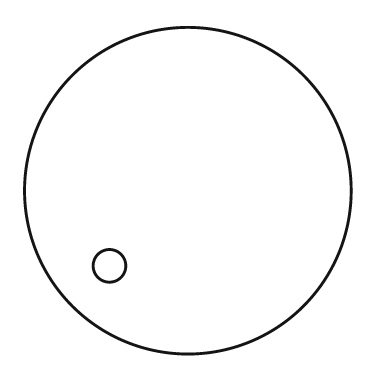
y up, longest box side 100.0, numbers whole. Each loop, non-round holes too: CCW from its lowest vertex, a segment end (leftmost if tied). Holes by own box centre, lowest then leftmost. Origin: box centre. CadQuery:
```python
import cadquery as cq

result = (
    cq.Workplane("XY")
    .moveTo(0.0, 0.0)
    .circle(50.0)
    .moveTo(-24.0, -23.0)
    .circle(5.0)
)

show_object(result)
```